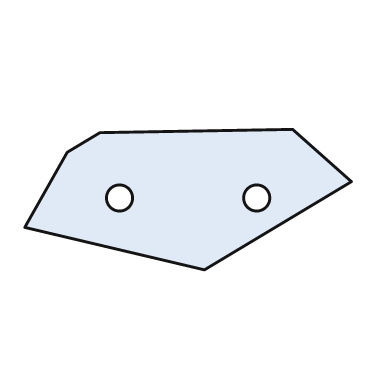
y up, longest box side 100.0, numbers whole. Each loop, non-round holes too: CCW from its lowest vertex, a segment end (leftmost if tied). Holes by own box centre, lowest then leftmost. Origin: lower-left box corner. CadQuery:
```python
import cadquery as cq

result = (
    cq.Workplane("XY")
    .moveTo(55.0, 0.0)
    .lineTo(100.0, 27.0)
    .lineTo(82.0, 43.0)
    .lineTo(23.0, 42.0)
    .lineTo(13.0, 36.0)
    .lineTo(0.0, 13.0)
    .close()
    .moveTo(29.0, 22.0)
    .circle(4.0)
    .moveTo(71.0, 22.0)
    .circle(4.0)
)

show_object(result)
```